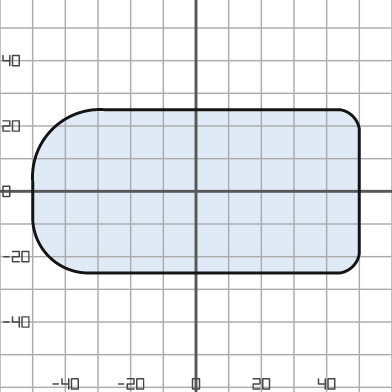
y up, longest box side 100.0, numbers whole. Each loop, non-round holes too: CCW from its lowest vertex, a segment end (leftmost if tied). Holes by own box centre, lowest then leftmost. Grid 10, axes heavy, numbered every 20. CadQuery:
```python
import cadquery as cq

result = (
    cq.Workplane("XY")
    .moveTo(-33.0, -25.0)
    .lineTo(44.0, -25.0)
    .threePointArc((48.0, -23.0), (50.0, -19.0))
    .lineTo(50.0, 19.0)
    .threePointArc((48.0, 23.0), (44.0, 25.0))
    .lineTo(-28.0, 25.0)
    .threePointArc((-44.0, 19.0), (-50.0, 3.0))
    .lineTo(-50.0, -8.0)
    .threePointArc((-45.0, -20.0), (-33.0, -25.0))
    .close()
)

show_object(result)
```